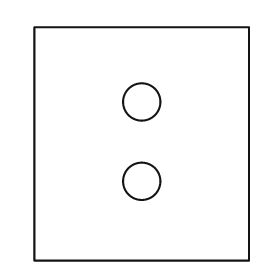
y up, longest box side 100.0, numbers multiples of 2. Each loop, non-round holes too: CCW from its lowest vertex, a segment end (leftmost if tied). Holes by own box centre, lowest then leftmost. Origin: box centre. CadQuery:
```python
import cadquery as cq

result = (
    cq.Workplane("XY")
    .moveTo(-46.0, -50.0)
    .lineTo(46.0, -50.0)
    .lineTo(46.0, 50.0)
    .lineTo(-46.0, 50.0)
    .close()
    .moveTo(0.0, -16.0)
    .circle(8.0)
    .moveTo(0.0, 18.0)
    .circle(8.0)
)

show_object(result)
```